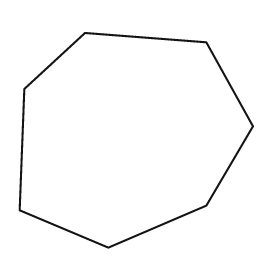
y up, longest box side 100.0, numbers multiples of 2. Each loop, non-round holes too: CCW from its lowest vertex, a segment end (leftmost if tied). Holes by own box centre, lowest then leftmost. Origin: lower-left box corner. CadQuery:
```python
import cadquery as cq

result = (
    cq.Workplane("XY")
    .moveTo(38.0, 0.0)
    .lineTo(80.0, 18.0)
    .lineTo(100.0, 52.0)
    .lineTo(80.0, 88.0)
    .lineTo(28.0, 92.0)
    .lineTo(2.0, 68.0)
    .lineTo(0.0, 16.0)
    .close()
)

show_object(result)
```